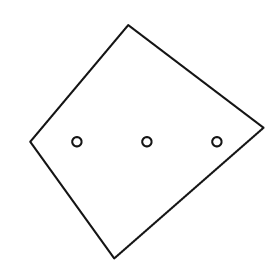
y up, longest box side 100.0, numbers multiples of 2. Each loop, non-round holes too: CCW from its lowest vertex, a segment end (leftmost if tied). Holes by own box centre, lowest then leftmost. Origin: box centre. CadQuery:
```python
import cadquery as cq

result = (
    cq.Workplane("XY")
    .moveTo(-14.0, -50.0)
    .lineTo(50.0, 6.0)
    .lineTo(-8.0, 50.0)
    .lineTo(-50.0, 0.0)
    .close()
    .moveTo(-30.0, 0.0)
    .circle(2.0)
    .moveTo(0.0, 0.0)
    .circle(2.0)
    .moveTo(30.0, 0.0)
    .circle(2.0)
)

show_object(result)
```